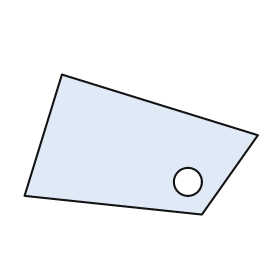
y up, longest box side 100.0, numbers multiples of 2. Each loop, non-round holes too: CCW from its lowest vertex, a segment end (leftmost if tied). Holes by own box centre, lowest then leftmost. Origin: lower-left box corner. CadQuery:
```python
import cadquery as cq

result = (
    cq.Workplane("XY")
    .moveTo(76.0, 0.0)
    .lineTo(100.0, 34.0)
    .lineTo(16.0, 60.0)
    .lineTo(0.0, 8.0)
    .close()
    .moveTo(70.0, 14.0)
    .circle(6.0)
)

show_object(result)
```